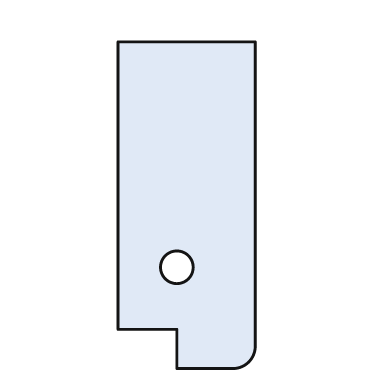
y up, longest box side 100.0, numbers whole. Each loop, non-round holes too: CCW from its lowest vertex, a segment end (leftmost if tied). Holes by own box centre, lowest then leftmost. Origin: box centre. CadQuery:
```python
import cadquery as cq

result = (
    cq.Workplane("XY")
    .moveTo(-3.0, -50.0)
    .lineTo(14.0, -50.0)
    .threePointArc((19.0, -48.0), (21.0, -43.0))
    .lineTo(21.0, 50.0)
    .lineTo(-21.0, 50.0)
    .lineTo(-21.0, -38.0)
    .lineTo(-3.0, -38.0)
    .close()
    .moveTo(-3.0, -19.0)
    .circle(5.0)
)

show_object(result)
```